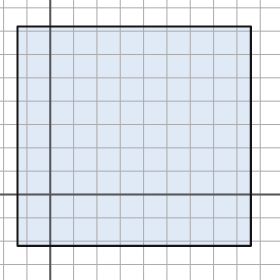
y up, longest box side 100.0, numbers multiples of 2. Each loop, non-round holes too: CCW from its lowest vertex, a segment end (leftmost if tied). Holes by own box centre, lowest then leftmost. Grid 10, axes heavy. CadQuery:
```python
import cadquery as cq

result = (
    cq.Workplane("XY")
    .moveTo(-14.0, -22.0)
    .lineTo(86.0, -22.0)
    .lineTo(86.0, 72.0)
    .lineTo(-14.0, 72.0)
    .close()
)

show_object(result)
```